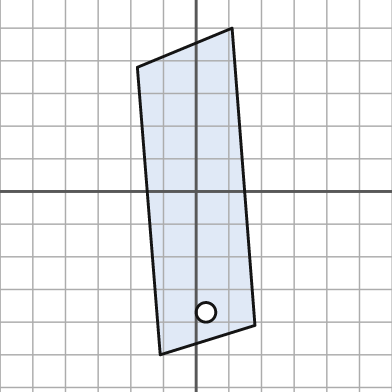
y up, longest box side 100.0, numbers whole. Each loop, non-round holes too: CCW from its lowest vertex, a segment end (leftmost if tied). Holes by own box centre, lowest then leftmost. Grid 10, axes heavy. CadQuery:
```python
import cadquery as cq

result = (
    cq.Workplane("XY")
    .moveTo(-11.0, -50.0)
    .lineTo(18.0, -41.0)
    .lineTo(11.0, 50.0)
    .lineTo(-18.0, 38.0)
    .close()
    .moveTo(3.0, -37.0)
    .circle(3.0)
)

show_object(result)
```